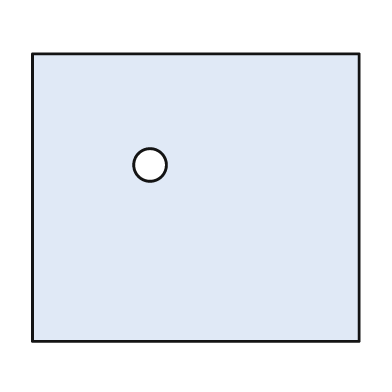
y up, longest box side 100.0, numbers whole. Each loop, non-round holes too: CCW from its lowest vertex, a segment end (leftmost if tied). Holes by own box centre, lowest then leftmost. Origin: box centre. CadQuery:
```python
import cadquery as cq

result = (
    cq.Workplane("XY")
    .moveTo(-50.0, -44.0)
    .lineTo(50.0, -44.0)
    .lineTo(50.0, 44.0)
    .lineTo(-50.0, 44.0)
    .close()
    .moveTo(-14.0, 10.0)
    .circle(5.0)
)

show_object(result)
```